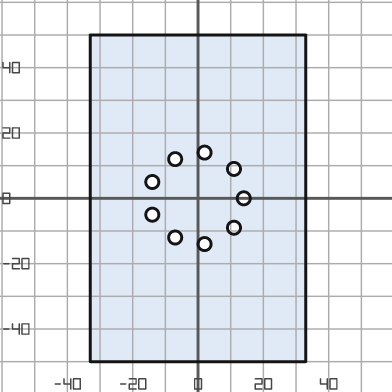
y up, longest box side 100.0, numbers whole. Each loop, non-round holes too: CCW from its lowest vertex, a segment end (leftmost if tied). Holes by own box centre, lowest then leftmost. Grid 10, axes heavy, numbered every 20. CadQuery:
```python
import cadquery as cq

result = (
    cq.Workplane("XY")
    .moveTo(-33.0, -50.0)
    .lineTo(33.0, -50.0)
    .lineTo(33.0, 50.0)
    .lineTo(-33.0, 50.0)
    .close()
    .moveTo(2.0, -14.0)
    .circle(2.0)
    .moveTo(-7.0, -12.0)
    .circle(2.0)
    .moveTo(11.0, -9.0)
    .circle(2.0)
    .moveTo(-14.0, -5.0)
    .circle(2.0)
    .moveTo(14.0, 0.0)
    .circle(2.0)
    .moveTo(-14.0, 5.0)
    .circle(2.0)
    .moveTo(11.0, 9.0)
    .circle(2.0)
    .moveTo(-7.0, 12.0)
    .circle(2.0)
    .moveTo(2.0, 14.0)
    .circle(2.0)
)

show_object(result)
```